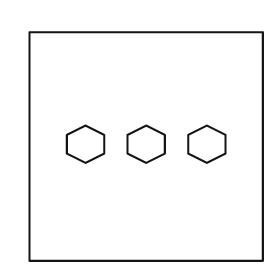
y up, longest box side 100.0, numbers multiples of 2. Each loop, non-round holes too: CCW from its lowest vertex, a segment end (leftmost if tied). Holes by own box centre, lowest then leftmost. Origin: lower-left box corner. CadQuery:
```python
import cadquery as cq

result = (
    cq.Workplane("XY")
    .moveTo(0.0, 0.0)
    .lineTo(100.0, 0.0)
    .lineTo(100.0, 98.0)
    .lineTo(0.0, 98.0)
    .close()
    .moveTo(24.0, 42.0)
    .lineTo(32.0, 46.0)
    .lineTo(32.0, 54.0)
    .lineTo(24.0, 58.0)
    .lineTo(16.0, 54.0)
    .lineTo(16.0, 46.0)
    .close()
    .moveTo(50.0, 42.0)
    .lineTo(58.0, 46.0)
    .lineTo(58.0, 54.0)
    .lineTo(50.0, 58.0)
    .lineTo(42.0, 54.0)
    .lineTo(42.0, 46.0)
    .close()
    .moveTo(76.0, 42.0)
    .lineTo(84.0, 46.0)
    .lineTo(84.0, 54.0)
    .lineTo(76.0, 58.0)
    .lineTo(68.0, 54.0)
    .lineTo(68.0, 46.0)
    .close()
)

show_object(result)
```